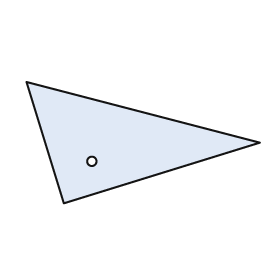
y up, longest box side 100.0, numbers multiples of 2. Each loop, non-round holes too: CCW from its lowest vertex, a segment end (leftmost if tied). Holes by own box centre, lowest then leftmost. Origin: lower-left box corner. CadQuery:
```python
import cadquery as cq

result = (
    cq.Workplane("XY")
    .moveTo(16.0, 0.0)
    .lineTo(100.0, 26.0)
    .lineTo(0.0, 52.0)
    .close()
    .moveTo(28.0, 18.0)
    .circle(2.0)
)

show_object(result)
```